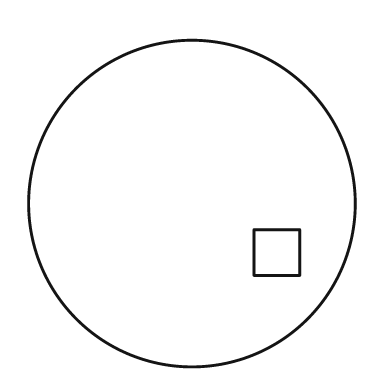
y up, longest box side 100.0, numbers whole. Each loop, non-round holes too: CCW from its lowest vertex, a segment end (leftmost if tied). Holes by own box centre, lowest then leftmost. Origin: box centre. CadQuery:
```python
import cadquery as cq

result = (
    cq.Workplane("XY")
    .moveTo(0.0, 0.0)
    .circle(50.0)
    .moveTo(19.0, -22.0)
    .lineTo(33.0, -22.0)
    .lineTo(33.0, -8.0)
    .lineTo(19.0, -8.0)
    .close()
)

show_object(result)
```